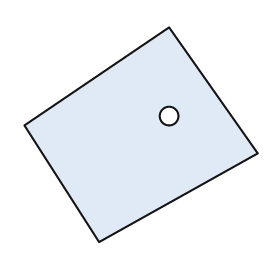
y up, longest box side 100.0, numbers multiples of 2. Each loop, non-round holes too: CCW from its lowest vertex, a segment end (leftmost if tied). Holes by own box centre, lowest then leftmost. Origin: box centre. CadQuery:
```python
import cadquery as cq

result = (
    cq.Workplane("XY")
    .moveTo(-18.0, -46.0)
    .lineTo(50.0, -8.0)
    .lineTo(12.0, 46.0)
    .lineTo(-50.0, 4.0)
    .close()
    .moveTo(12.0, 8.0)
    .circle(4.0)
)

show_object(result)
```